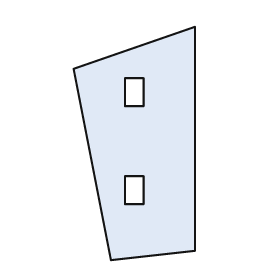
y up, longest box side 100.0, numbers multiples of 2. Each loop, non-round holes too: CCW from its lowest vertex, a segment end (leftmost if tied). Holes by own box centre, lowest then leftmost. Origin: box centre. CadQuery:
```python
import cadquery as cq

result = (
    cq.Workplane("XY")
    .moveTo(-10.0, -50.0)
    .lineTo(26.0, -46.0)
    .lineTo(26.0, 50.0)
    .lineTo(-26.0, 32.0)
    .close()
    .moveTo(-4.0, -26.0)
    .lineTo(4.0, -26.0)
    .lineTo(4.0, -14.0)
    .lineTo(-4.0, -14.0)
    .close()
    .moveTo(-4.0, 16.0)
    .lineTo(4.0, 16.0)
    .lineTo(4.0, 28.0)
    .lineTo(-4.0, 28.0)
    .close()
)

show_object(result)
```